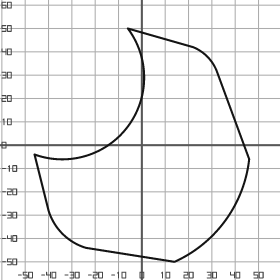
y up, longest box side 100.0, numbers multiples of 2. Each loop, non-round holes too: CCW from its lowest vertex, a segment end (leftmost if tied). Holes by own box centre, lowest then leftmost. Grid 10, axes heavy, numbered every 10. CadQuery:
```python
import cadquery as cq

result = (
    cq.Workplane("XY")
    .moveTo(14.0, -50.0)
    .threePointArc((36.0, -32.0), (46.0, -6.0))
    .lineTo(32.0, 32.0)
    .threePointArc((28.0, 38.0), (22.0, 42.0))
    .lineTo(-6.0, 50.0)
    .threePointArc((-6.0, 8.0), (-46.0, -4.0))
    .lineTo(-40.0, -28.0)
    .threePointArc((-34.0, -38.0), (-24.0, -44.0))
    .close()
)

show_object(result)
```